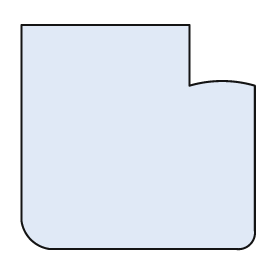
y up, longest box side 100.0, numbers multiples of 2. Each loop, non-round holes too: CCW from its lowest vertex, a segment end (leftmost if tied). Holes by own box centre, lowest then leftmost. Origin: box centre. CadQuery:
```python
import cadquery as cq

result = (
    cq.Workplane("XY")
    .moveTo(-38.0, -48.0)
    .lineTo(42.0, -48.0)
    .threePointArc((48.0, -46.0), (50.0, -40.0))
    .lineTo(50.0, 22.0)
    .threePointArc((36.0, 24.0), (22.0, 22.0))
    .lineTo(22.0, 48.0)
    .lineTo(-50.0, 48.0)
    .lineTo(-50.0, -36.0)
    .threePointArc((-46.0, -44.0), (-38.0, -48.0))
    .close()
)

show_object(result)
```